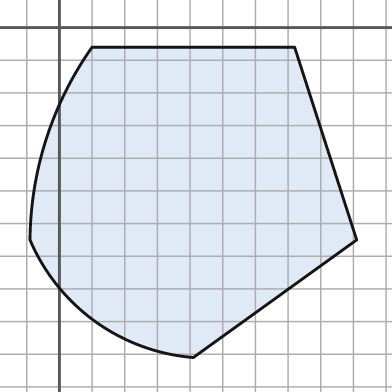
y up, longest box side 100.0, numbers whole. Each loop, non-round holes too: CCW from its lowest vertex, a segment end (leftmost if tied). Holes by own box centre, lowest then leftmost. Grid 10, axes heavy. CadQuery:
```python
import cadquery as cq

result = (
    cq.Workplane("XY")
    .moveTo(41.0, -101.0)
    .lineTo(91.0, -65.0)
    .lineTo(72.0, -6.0)
    .lineTo(10.0, -6.0)
    .threePointArc((-4.0, -34.0), (-9.0, -65.0))
    .threePointArc((11.0, -90.0), (41.0, -101.0))
    .close()
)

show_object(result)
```